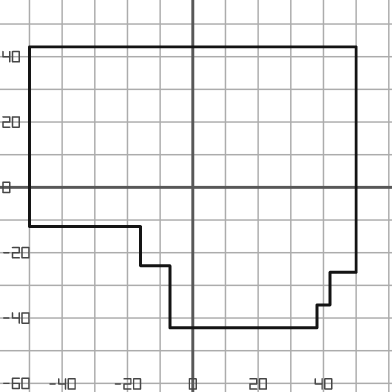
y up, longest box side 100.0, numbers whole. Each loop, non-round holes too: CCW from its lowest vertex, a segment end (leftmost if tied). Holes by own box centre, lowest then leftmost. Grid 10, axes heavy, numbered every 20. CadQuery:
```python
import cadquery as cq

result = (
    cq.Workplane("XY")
    .moveTo(-7.0, -43.0)
    .lineTo(38.0, -43.0)
    .lineTo(38.0, -36.0)
    .lineTo(42.0, -36.0)
    .lineTo(42.0, -26.0)
    .lineTo(50.0, -26.0)
    .lineTo(50.0, 43.0)
    .lineTo(-50.0, 43.0)
    .lineTo(-50.0, -12.0)
    .lineTo(-16.0, -12.0)
    .lineTo(-16.0, -24.0)
    .lineTo(-7.0, -24.0)
    .close()
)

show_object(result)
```